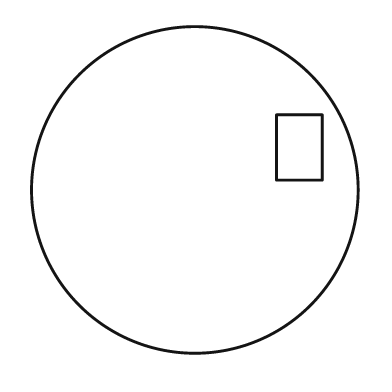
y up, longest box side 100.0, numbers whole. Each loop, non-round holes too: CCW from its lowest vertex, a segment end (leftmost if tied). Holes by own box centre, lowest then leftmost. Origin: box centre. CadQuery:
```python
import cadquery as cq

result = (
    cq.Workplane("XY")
    .moveTo(0.0, 0.0)
    .circle(50.0)
    .moveTo(25.0, 3.0)
    .lineTo(39.0, 3.0)
    .lineTo(39.0, 23.0)
    .lineTo(25.0, 23.0)
    .close()
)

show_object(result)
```